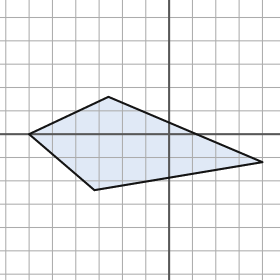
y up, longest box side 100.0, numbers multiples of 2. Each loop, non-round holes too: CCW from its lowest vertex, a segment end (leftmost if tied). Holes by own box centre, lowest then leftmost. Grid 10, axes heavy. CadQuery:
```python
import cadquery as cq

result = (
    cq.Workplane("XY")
    .moveTo(-32.0, -24.0)
    .lineTo(40.0, -12.0)
    .lineTo(-26.0, 16.0)
    .lineTo(-60.0, 0.0)
    .close()
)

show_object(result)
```